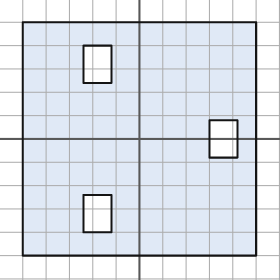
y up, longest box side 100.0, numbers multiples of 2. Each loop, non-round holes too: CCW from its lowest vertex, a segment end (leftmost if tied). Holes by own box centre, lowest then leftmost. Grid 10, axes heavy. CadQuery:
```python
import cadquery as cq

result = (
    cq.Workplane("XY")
    .moveTo(-50.0, -50.0)
    .lineTo(50.0, -50.0)
    .lineTo(50.0, 50.0)
    .lineTo(-50.0, 50.0)
    .close()
    .moveTo(-24.0, -40.0)
    .lineTo(-12.0, -40.0)
    .lineTo(-12.0, -24.0)
    .lineTo(-24.0, -24.0)
    .close()
    .moveTo(30.0, -8.0)
    .lineTo(42.0, -8.0)
    .lineTo(42.0, 8.0)
    .lineTo(30.0, 8.0)
    .close()
    .moveTo(-24.0, 24.0)
    .lineTo(-12.0, 24.0)
    .lineTo(-12.0, 40.0)
    .lineTo(-24.0, 40.0)
    .close()
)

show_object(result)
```